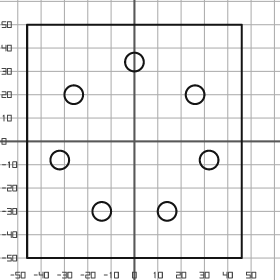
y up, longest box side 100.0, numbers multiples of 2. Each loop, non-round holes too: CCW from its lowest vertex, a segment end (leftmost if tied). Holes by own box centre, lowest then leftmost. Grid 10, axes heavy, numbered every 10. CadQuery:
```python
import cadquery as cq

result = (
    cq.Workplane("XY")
    .moveTo(-46.0, -50.0)
    .lineTo(46.0, -50.0)
    .lineTo(46.0, 50.0)
    .lineTo(-46.0, 50.0)
    .close()
    .moveTo(-14.0, -30.0)
    .circle(4.0)
    .moveTo(14.0, -30.0)
    .circle(4.0)
    .moveTo(-32.0, -8.0)
    .circle(4.0)
    .moveTo(32.0, -8.0)
    .circle(4.0)
    .moveTo(-26.0, 20.0)
    .circle(4.0)
    .moveTo(26.0, 20.0)
    .circle(4.0)
    .moveTo(0.0, 34.0)
    .circle(4.0)
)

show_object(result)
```